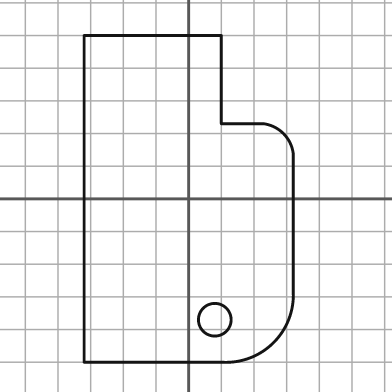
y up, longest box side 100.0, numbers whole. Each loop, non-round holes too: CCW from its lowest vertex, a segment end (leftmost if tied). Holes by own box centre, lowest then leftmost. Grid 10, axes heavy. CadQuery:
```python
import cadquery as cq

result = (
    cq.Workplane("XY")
    .moveTo(-32.0, -50.0)
    .lineTo(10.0, -50.0)
    .threePointArc((26.0, -44.0), (32.0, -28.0))
    .lineTo(32.0, 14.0)
    .threePointArc((29.0, 20.0), (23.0, 23.0))
    .lineTo(10.0, 23.0)
    .lineTo(10.0, 50.0)
    .lineTo(-32.0, 50.0)
    .close()
    .moveTo(8.0, -37.0)
    .circle(5.0)
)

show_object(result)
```